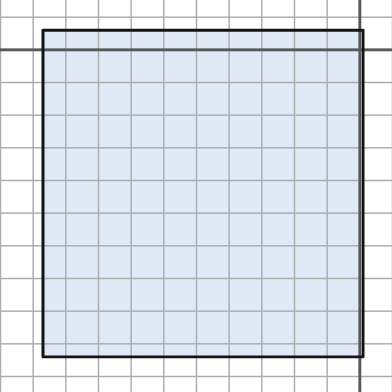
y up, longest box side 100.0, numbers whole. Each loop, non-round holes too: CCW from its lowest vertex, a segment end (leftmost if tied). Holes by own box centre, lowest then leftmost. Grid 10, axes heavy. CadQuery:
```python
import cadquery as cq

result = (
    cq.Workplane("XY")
    .moveTo(-97.0, -94.0)
    .lineTo(1.0, -94.0)
    .lineTo(1.0, 6.0)
    .lineTo(-97.0, 6.0)
    .close()
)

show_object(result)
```